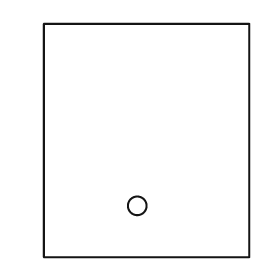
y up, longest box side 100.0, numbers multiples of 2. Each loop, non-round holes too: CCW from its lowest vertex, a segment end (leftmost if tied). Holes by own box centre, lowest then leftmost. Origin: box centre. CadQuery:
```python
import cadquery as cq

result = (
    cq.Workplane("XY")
    .moveTo(-44.0, -50.0)
    .lineTo(44.0, -50.0)
    .lineTo(44.0, 50.0)
    .lineTo(-44.0, 50.0)
    .close()
    .moveTo(-4.0, -28.0)
    .circle(4.0)
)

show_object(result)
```